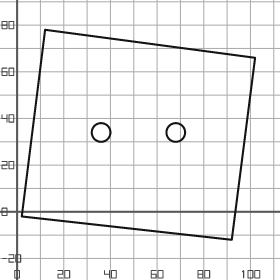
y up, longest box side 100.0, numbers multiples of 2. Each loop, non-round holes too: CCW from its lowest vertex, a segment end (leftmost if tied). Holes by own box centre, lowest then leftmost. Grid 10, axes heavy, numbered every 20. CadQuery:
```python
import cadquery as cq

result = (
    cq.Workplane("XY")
    .moveTo(92.0, -12.0)
    .lineTo(102.0, 66.0)
    .lineTo(12.0, 78.0)
    .lineTo(2.0, -2.0)
    .close()
    .moveTo(36.0, 34.0)
    .circle(4.0)
    .moveTo(68.0, 34.0)
    .circle(4.0)
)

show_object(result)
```